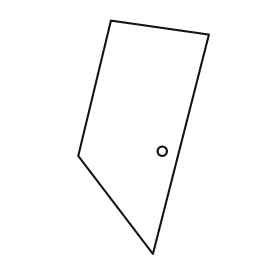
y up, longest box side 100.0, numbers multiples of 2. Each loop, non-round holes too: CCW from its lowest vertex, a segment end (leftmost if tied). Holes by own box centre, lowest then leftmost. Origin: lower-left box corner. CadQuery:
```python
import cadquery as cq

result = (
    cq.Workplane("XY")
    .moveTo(32.0, 0.0)
    .lineTo(56.0, 94.0)
    .lineTo(14.0, 100.0)
    .lineTo(0.0, 42.0)
    .close()
    .moveTo(36.0, 44.0)
    .circle(2.0)
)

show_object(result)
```